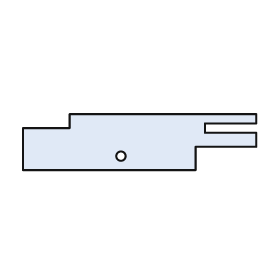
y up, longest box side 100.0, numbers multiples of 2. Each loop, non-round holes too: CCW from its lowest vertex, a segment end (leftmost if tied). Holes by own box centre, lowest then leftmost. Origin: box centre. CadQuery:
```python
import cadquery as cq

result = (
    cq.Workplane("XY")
    .moveTo(-50.0, -12.0)
    .lineTo(24.0, -12.0)
    .lineTo(24.0, -2.0)
    .lineTo(50.0, -2.0)
    .lineTo(50.0, 4.0)
    .lineTo(28.0, 4.0)
    .lineTo(28.0, 8.0)
    .lineTo(50.0, 8.0)
    .lineTo(50.0, 12.0)
    .lineTo(-30.0, 12.0)
    .lineTo(-30.0, 6.0)
    .lineTo(-50.0, 6.0)
    .close()
    .moveTo(-8.0, -6.0)
    .circle(2.0)
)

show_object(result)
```